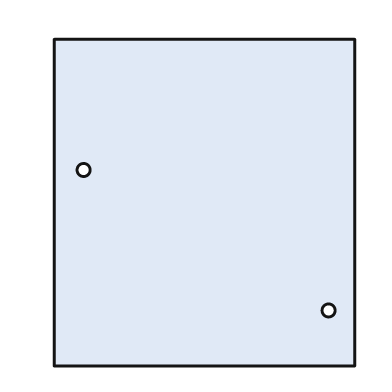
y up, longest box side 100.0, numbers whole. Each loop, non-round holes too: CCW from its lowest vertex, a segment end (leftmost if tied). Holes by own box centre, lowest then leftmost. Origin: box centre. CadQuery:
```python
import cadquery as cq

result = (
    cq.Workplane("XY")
    .moveTo(-46.0, -50.0)
    .lineTo(46.0, -50.0)
    .lineTo(46.0, 50.0)
    .lineTo(-46.0, 50.0)
    .close()
    .moveTo(38.0, -33.0)
    .circle(2.0)
    .moveTo(-37.0, 10.0)
    .circle(2.0)
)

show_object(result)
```